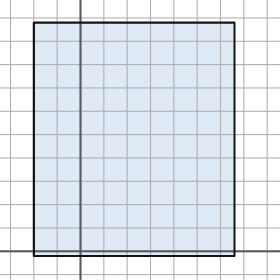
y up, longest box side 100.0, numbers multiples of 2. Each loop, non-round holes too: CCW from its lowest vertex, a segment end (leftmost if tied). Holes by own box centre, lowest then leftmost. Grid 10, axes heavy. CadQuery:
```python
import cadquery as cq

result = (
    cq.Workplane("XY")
    .moveTo(-20.0, -2.0)
    .lineTo(66.0, -2.0)
    .lineTo(66.0, 98.0)
    .lineTo(-20.0, 98.0)
    .close()
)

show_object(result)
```